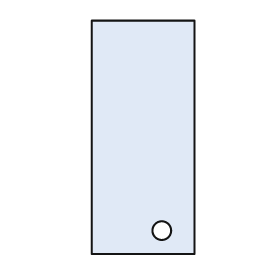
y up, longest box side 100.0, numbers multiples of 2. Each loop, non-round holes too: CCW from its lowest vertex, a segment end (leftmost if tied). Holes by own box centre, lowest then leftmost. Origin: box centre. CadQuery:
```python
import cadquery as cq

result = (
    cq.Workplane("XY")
    .moveTo(-22.0, -50.0)
    .lineTo(22.0, -50.0)
    .lineTo(22.0, 50.0)
    .lineTo(-22.0, 50.0)
    .close()
    .moveTo(8.0, -40.0)
    .circle(4.0)
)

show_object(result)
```